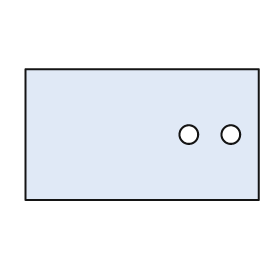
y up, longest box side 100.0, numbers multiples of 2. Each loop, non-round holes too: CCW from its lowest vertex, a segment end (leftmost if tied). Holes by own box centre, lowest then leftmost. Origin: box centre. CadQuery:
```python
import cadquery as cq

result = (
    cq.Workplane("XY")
    .moveTo(-50.0, -28.0)
    .lineTo(50.0, -28.0)
    .lineTo(50.0, 28.0)
    .lineTo(-50.0, 28.0)
    .close()
    .moveTo(20.0, 0.0)
    .circle(4.0)
    .moveTo(38.0, 0.0)
    .circle(4.0)
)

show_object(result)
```